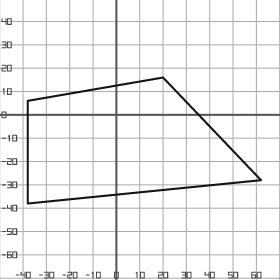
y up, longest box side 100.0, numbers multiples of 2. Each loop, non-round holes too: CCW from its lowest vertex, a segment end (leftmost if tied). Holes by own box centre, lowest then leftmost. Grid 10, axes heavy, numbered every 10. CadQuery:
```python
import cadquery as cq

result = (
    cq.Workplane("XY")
    .moveTo(-38.0, -38.0)
    .lineTo(62.0, -28.0)
    .lineTo(20.0, 16.0)
    .lineTo(-38.0, 6.0)
    .close()
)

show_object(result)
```